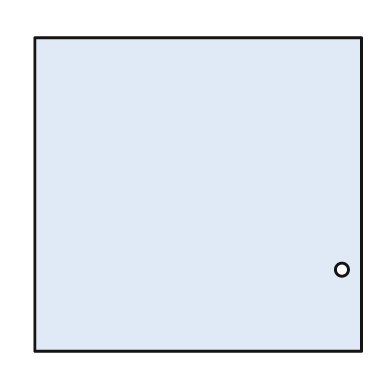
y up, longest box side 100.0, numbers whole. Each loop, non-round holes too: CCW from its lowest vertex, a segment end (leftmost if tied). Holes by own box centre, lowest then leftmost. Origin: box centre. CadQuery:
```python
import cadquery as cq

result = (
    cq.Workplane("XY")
    .moveTo(-50.0, -48.0)
    .lineTo(50.0, -48.0)
    .lineTo(50.0, 48.0)
    .lineTo(-50.0, 48.0)
    .close()
    .moveTo(44.0, -23.0)
    .circle(2.0)
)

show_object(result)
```